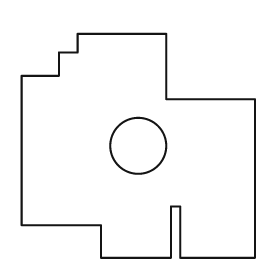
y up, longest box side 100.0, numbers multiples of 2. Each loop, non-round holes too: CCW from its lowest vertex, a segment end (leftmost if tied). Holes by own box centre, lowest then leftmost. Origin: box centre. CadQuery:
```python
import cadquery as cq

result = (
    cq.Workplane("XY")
    .moveTo(-16.0, -48.0)
    .lineTo(14.0, -48.0)
    .lineTo(14.0, -26.0)
    .lineTo(18.0, -26.0)
    .lineTo(18.0, -48.0)
    .lineTo(50.0, -48.0)
    .lineTo(50.0, 20.0)
    .lineTo(12.0, 20.0)
    .lineTo(12.0, 48.0)
    .lineTo(-26.0, 48.0)
    .lineTo(-26.0, 40.0)
    .lineTo(-34.0, 40.0)
    .lineTo(-34.0, 30.0)
    .lineTo(-50.0, 30.0)
    .lineTo(-50.0, -34.0)
    .lineTo(-16.0, -34.0)
    .close()
    .moveTo(0.0, 0.0)
    .circle(12.0)
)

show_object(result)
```